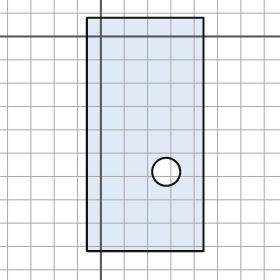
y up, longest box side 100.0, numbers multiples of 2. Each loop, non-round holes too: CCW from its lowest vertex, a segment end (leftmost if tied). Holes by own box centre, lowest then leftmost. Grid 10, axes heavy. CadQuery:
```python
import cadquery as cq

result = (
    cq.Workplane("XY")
    .moveTo(-6.0, -92.0)
    .lineTo(44.0, -92.0)
    .lineTo(44.0, 8.0)
    .lineTo(-6.0, 8.0)
    .close()
    .moveTo(28.0, -58.0)
    .circle(6.0)
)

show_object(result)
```